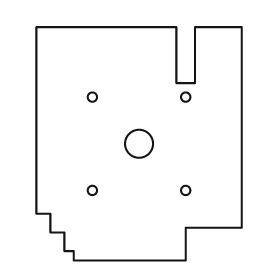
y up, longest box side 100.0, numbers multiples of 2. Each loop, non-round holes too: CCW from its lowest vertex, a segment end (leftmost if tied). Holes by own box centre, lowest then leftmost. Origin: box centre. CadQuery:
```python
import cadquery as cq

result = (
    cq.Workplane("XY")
    .moveTo(-28.0, -50.0)
    .lineTo(20.0, -50.0)
    .lineTo(20.0, -36.0)
    .lineTo(44.0, -36.0)
    .lineTo(44.0, 50.0)
    .lineTo(24.0, 50.0)
    .lineTo(24.0, 26.0)
    .lineTo(16.0, 26.0)
    .lineTo(16.0, 50.0)
    .lineTo(-44.0, 50.0)
    .lineTo(-44.0, -30.0)
    .lineTo(-38.0, -30.0)
    .lineTo(-38.0, -38.0)
    .lineTo(-32.0, -38.0)
    .lineTo(-32.0, -46.0)
    .lineTo(-28.0, -46.0)
    .close()
    .moveTo(-20.0, -20.0)
    .circle(2.0)
    .moveTo(20.0, -20.0)
    .circle(2.0)
    .moveTo(0.0, 0.0)
    .circle(6.0)
    .moveTo(-20.0, 20.0)
    .circle(2.0)
    .moveTo(20.0, 20.0)
    .circle(2.0)
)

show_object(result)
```